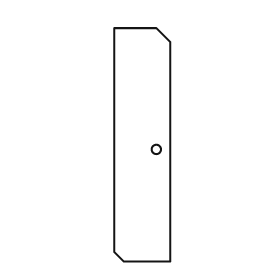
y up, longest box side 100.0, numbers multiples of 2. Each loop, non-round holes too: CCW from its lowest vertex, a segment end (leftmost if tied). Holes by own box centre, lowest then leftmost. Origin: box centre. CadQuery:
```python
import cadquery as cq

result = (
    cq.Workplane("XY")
    .moveTo(-8.0, -50.0)
    .lineTo(12.0, -50.0)
    .lineTo(12.0, 44.0)
    .lineTo(6.0, 50.0)
    .lineTo(-12.0, 50.0)
    .lineTo(-12.0, -46.0)
    .close()
    .moveTo(6.0, -2.0)
    .circle(2.0)
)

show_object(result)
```